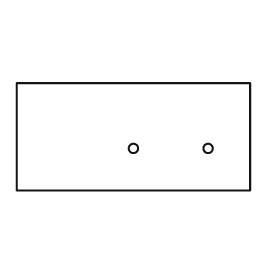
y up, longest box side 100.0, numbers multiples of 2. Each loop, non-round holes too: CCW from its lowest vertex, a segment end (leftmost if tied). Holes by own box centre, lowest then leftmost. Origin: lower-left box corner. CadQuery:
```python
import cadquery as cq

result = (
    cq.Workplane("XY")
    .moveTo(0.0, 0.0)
    .lineTo(100.0, 0.0)
    .lineTo(100.0, 46.0)
    .lineTo(0.0, 46.0)
    .close()
    .moveTo(50.0, 18.0)
    .circle(2.0)
    .moveTo(82.0, 18.0)
    .circle(2.0)
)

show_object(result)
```